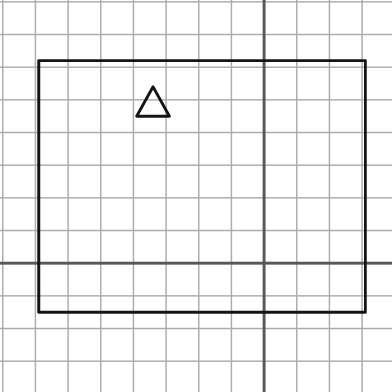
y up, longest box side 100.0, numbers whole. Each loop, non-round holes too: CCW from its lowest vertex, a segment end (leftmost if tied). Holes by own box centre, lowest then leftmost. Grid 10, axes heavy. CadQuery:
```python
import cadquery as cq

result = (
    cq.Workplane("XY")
    .moveTo(-69.0, -15.0)
    .lineTo(31.0, -15.0)
    .lineTo(31.0, 62.0)
    .lineTo(-69.0, 62.0)
    .close()
    .moveTo(-39.0, 45.0)
    .lineTo(-29.0, 45.0)
    .lineTo(-34.0, 54.0)
    .close()
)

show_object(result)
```